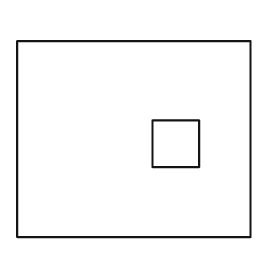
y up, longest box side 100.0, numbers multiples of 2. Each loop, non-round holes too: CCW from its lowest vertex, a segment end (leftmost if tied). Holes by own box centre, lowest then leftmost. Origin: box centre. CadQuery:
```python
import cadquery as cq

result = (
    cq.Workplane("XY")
    .moveTo(-50.0, -42.0)
    .lineTo(50.0, -42.0)
    .lineTo(50.0, 42.0)
    .lineTo(-50.0, 42.0)
    .close()
    .moveTo(8.0, -12.0)
    .lineTo(28.0, -12.0)
    .lineTo(28.0, 8.0)
    .lineTo(8.0, 8.0)
    .close()
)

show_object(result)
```